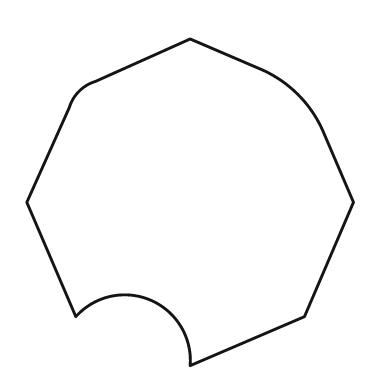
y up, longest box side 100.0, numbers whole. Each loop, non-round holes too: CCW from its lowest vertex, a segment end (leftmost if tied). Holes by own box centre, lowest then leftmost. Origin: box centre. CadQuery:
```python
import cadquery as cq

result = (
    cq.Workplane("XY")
    .moveTo(0.0, -50.0)
    .lineTo(35.0, -35.0)
    .lineTo(50.0, 0.0)
    .lineTo(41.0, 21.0)
    .threePointArc((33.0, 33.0), (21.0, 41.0))
    .lineTo(0.0, 50.0)
    .lineTo(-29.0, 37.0)
    .threePointArc((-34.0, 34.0), (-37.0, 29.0))
    .lineTo(-50.0, 0.0)
    .lineTo(-35.0, -35.0)
    .threePointArc((-12.0, -30.0), (0.0, -50.0))
    .close()
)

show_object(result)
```